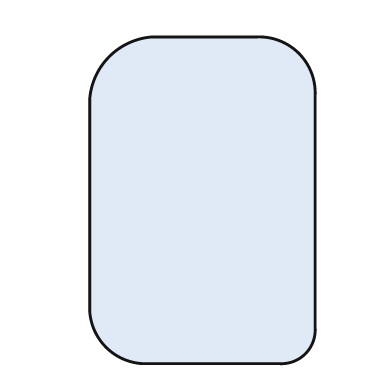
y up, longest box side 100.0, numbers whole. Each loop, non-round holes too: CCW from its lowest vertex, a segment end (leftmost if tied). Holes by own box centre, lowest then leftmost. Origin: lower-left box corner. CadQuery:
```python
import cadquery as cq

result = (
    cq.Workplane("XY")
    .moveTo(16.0, 0.0)
    .lineTo(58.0, 0.0)
    .threePointArc((66.0, 3.0), (69.0, 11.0))
    .lineTo(69.0, 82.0)
    .threePointArc((64.0, 95.0), (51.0, 100.0))
    .lineTo(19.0, 100.0)
    .threePointArc((6.0, 94.0), (0.0, 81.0))
    .lineTo(0.0, 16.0)
    .threePointArc((5.0, 5.0), (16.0, 0.0))
    .close()
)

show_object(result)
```